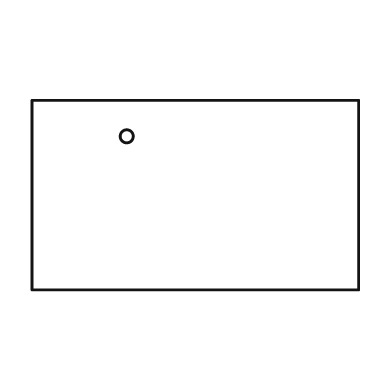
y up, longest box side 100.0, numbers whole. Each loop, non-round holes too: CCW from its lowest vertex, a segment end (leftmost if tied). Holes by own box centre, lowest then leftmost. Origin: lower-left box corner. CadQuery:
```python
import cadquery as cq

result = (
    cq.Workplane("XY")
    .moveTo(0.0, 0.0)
    .lineTo(100.0, 0.0)
    .lineTo(100.0, 58.0)
    .lineTo(0.0, 58.0)
    .close()
    .moveTo(29.0, 47.0)
    .circle(2.0)
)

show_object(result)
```